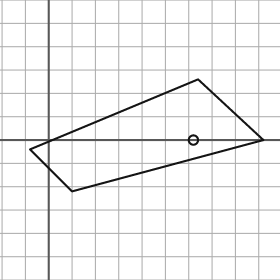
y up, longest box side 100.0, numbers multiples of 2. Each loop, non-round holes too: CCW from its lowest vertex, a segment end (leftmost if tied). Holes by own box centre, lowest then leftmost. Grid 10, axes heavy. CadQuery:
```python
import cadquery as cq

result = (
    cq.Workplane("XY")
    .moveTo(10.0, -22.0)
    .lineTo(92.0, 0.0)
    .lineTo(64.0, 26.0)
    .lineTo(-8.0, -4.0)
    .close()
    .moveTo(62.0, 0.0)
    .circle(2.0)
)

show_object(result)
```